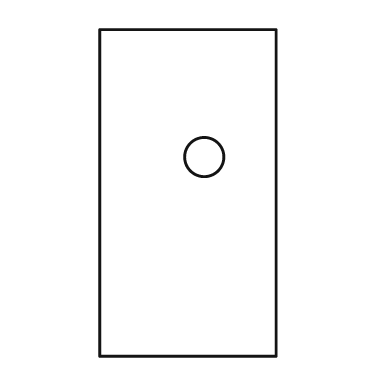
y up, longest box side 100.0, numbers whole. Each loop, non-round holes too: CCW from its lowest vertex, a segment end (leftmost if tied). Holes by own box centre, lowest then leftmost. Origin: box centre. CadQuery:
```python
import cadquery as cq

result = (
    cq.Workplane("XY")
    .moveTo(-27.0, -50.0)
    .lineTo(27.0, -50.0)
    .lineTo(27.0, 50.0)
    .lineTo(-27.0, 50.0)
    .close()
    .moveTo(5.0, 11.0)
    .circle(6.0)
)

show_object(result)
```